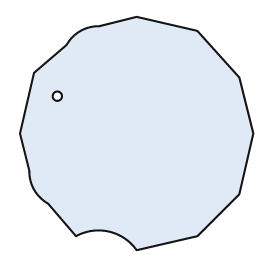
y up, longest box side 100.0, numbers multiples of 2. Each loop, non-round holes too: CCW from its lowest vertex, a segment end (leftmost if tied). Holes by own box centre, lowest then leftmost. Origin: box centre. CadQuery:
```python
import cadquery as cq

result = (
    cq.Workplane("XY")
    .moveTo(0.0, -50.0)
    .lineTo(26.0, -44.0)
    .lineTo(44.0, -26.0)
    .lineTo(50.0, 0.0)
    .lineTo(44.0, 24.0)
    .lineTo(26.0, 44.0)
    .lineTo(0.0, 50.0)
    .lineTo(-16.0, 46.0)
    .threePointArc((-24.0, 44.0), (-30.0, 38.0))
    .lineTo(-44.0, 26.0)
    .lineTo(-50.0, 0.0)
    .lineTo(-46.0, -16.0)
    .threePointArc((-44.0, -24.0), (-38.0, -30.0))
    .lineTo(-26.0, -44.0)
    .threePointArc((-12.0, -42.0), (0.0, -50.0))
    .close()
    .moveTo(-34.0, 16.0)
    .circle(2.0)
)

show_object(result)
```